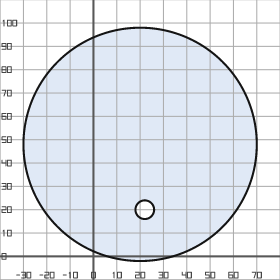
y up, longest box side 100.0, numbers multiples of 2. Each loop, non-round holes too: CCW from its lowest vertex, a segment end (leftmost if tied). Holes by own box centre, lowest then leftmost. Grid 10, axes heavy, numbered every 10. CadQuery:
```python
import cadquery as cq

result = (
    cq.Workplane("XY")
    .moveTo(20.0, 48.0)
    .circle(50.0)
    .moveTo(22.0, 20.0)
    .circle(4.0)
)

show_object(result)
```